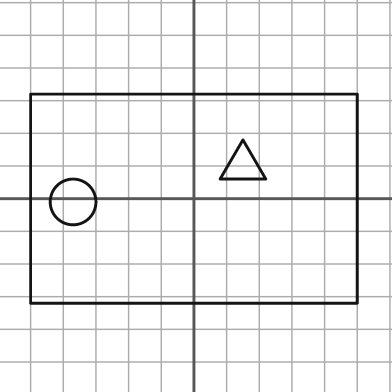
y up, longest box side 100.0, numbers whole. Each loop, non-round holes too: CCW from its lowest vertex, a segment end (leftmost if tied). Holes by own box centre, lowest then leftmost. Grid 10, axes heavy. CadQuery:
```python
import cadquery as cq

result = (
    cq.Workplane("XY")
    .moveTo(-50.0, -32.0)
    .lineTo(50.0, -32.0)
    .lineTo(50.0, 32.0)
    .lineTo(-50.0, 32.0)
    .close()
    .moveTo(-37.0, -1.0)
    .circle(7.0)
    .moveTo(8.0, 6.0)
    .lineTo(22.0, 6.0)
    .lineTo(15.0, 18.0)
    .close()
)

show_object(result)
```